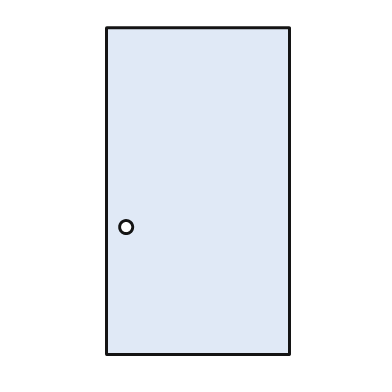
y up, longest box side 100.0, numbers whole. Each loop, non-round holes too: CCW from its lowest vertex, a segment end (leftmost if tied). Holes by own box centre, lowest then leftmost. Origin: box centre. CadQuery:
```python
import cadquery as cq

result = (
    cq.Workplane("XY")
    .moveTo(-28.0, -50.0)
    .lineTo(28.0, -50.0)
    .lineTo(28.0, 50.0)
    .lineTo(-28.0, 50.0)
    .close()
    .moveTo(-22.0, -11.0)
    .circle(2.0)
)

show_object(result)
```